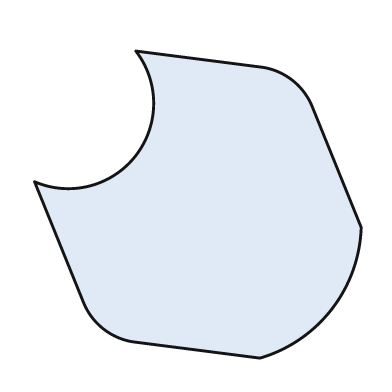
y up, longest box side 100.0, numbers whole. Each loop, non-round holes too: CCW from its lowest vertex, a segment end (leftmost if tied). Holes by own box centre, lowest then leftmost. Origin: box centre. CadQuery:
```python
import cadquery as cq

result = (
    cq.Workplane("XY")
    .moveTo(19.0, -47.0)
    .threePointArc((41.0, -32.0), (50.0, -7.0))
    .lineTo(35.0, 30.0)
    .threePointArc((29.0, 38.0), (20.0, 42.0))
    .lineTo(-19.0, 47.0)
    .threePointArc((-19.0, 15.0), (-50.0, 7.0))
    .lineTo(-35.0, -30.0)
    .threePointArc((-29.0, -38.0), (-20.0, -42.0))
    .close()
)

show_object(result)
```